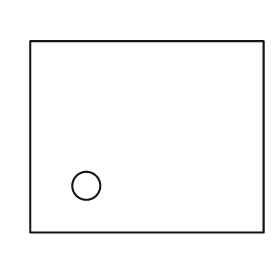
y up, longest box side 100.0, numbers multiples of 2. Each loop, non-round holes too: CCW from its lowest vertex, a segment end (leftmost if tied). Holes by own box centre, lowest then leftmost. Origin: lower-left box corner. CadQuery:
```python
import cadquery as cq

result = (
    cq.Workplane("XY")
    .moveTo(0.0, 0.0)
    .lineTo(100.0, 0.0)
    .lineTo(100.0, 82.0)
    .lineTo(0.0, 82.0)
    .close()
    .moveTo(24.0, 20.0)
    .circle(6.0)
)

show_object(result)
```